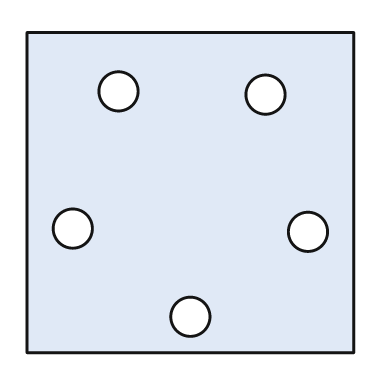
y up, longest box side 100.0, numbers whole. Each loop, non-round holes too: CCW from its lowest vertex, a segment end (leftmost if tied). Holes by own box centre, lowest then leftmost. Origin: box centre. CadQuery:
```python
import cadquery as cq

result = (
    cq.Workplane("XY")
    .moveTo(-50.0, -49.0)
    .lineTo(50.0, -49.0)
    .lineTo(50.0, 49.0)
    .lineTo(-50.0, 49.0)
    .close()
    .moveTo(0.0, -38.0)
    .circle(6.0)
    .moveTo(36.0, -12.0)
    .circle(6.0)
    .moveTo(-36.0, -11.0)
    .circle(6.0)
    .moveTo(23.0, 30.0)
    .circle(6.0)
    .moveTo(-22.0, 31.0)
    .circle(6.0)
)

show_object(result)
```